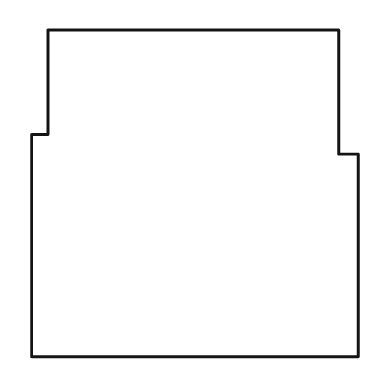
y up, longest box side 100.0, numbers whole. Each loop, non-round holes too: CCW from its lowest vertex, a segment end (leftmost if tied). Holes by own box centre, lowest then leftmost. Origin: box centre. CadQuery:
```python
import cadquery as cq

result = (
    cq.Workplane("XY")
    .moveTo(-50.0, -50.0)
    .lineTo(50.0, -50.0)
    .lineTo(50.0, 12.0)
    .lineTo(44.0, 12.0)
    .lineTo(44.0, 50.0)
    .lineTo(-45.0, 50.0)
    .lineTo(-45.0, 18.0)
    .lineTo(-50.0, 18.0)
    .close()
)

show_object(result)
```